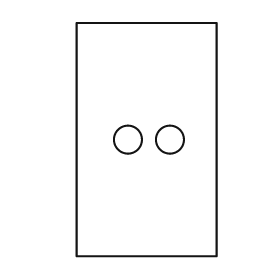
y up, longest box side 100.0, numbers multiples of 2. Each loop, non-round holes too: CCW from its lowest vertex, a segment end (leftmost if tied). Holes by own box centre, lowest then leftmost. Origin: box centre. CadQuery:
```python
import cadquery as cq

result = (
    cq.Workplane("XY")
    .moveTo(-30.0, -50.0)
    .lineTo(30.0, -50.0)
    .lineTo(30.0, 50.0)
    .lineTo(-30.0, 50.0)
    .close()
    .moveTo(-8.0, 0.0)
    .circle(6.0)
    .moveTo(10.0, 0.0)
    .circle(6.0)
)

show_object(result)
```